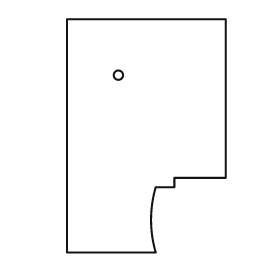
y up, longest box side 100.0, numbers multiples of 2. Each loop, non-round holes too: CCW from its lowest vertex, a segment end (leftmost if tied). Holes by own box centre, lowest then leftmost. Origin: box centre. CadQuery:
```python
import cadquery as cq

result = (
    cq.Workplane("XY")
    .moveTo(-34.0, -50.0)
    .lineTo(4.0, -50.0)
    .threePointArc((2.0, -36.0), (4.0, -22.0))
    .lineTo(12.0, -22.0)
    .lineTo(12.0, -18.0)
    .lineTo(34.0, -18.0)
    .lineTo(34.0, 50.0)
    .lineTo(-34.0, 50.0)
    .close()
    .moveTo(-12.0, 26.0)
    .circle(2.0)
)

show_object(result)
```